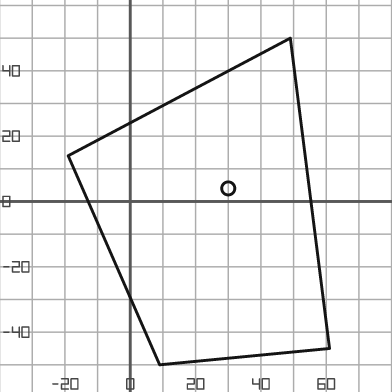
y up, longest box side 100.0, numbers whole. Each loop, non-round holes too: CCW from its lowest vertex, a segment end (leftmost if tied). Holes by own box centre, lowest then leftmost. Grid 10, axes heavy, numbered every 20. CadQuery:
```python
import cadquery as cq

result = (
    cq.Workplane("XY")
    .moveTo(9.0, -50.0)
    .lineTo(61.0, -45.0)
    .lineTo(49.0, 50.0)
    .lineTo(-19.0, 14.0)
    .close()
    .moveTo(30.0, 4.0)
    .circle(2.0)
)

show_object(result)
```